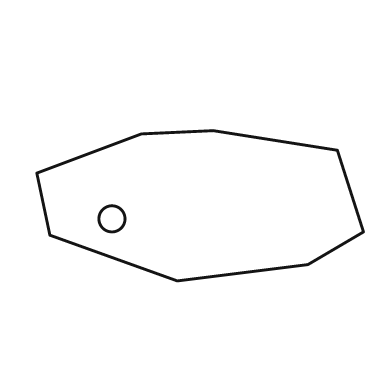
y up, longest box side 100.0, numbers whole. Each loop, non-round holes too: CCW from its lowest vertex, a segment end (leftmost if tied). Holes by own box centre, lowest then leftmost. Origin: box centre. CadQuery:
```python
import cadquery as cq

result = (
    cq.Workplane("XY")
    .moveTo(-7.0, -23.0)
    .lineTo(33.0, -18.0)
    .lineTo(50.0, -8.0)
    .lineTo(42.0, 17.0)
    .lineTo(4.0, 23.0)
    .lineTo(-18.0, 22.0)
    .lineTo(-50.0, 10.0)
    .lineTo(-46.0, -9.0)
    .close()
    .moveTo(-27.0, -4.0)
    .circle(4.0)
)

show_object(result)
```